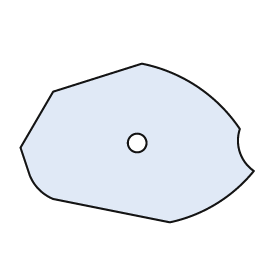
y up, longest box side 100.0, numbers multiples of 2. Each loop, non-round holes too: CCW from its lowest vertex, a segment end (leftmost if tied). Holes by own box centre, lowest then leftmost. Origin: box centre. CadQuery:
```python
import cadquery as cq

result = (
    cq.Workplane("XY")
    .moveTo(14.0, -34.0)
    .threePointArc((34.0, -26.0), (50.0, -12.0))
    .threePointArc((44.0, -4.0), (44.0, 6.0))
    .threePointArc((26.0, 24.0), (2.0, 34.0))
    .lineTo(-36.0, 22.0)
    .lineTo(-50.0, -2.0)
    .lineTo(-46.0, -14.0)
    .threePointArc((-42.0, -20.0), (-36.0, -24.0))
    .close()
    .moveTo(0.0, 0.0)
    .circle(4.0)
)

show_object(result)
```